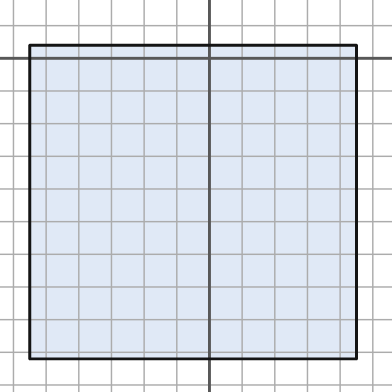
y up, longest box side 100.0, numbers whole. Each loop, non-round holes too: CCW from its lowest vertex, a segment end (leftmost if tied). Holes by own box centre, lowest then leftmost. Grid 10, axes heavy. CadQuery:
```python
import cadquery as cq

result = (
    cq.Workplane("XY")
    .moveTo(-55.0, -92.0)
    .lineTo(45.0, -92.0)
    .lineTo(45.0, 4.0)
    .lineTo(-55.0, 4.0)
    .close()
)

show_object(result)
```